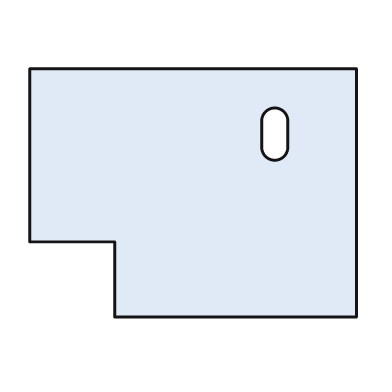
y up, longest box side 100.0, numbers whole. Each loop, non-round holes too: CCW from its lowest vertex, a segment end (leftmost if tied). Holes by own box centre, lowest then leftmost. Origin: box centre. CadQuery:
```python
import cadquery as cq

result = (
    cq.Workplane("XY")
    .moveTo(-24.0, -38.0)
    .lineTo(50.0, -38.0)
    .lineTo(50.0, 38.0)
    .lineTo(-50.0, 38.0)
    .lineTo(-50.0, -15.0)
    .lineTo(-24.0, -15.0)
    .close()
    .moveTo(21.0, 14.0)
    .threePointArc((25.0, 10.0), (29.0, 14.0))
    .lineTo(29.0, 22.0)
    .threePointArc((25.0, 26.0), (21.0, 22.0))
    .close()
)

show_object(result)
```